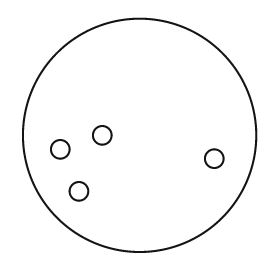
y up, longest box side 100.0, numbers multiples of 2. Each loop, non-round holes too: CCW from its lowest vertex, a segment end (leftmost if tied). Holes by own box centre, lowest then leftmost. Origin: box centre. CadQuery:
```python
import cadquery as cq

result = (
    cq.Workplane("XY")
    .moveTo(0.0, 0.0)
    .circle(50.0)
    .moveTo(-26.0, -24.0)
    .circle(4.0)
    .moveTo(32.0, -10.0)
    .circle(4.0)
    .moveTo(-34.0, -6.0)
    .circle(4.0)
    .moveTo(-16.0, 0.0)
    .circle(4.0)
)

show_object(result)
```